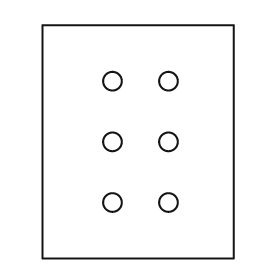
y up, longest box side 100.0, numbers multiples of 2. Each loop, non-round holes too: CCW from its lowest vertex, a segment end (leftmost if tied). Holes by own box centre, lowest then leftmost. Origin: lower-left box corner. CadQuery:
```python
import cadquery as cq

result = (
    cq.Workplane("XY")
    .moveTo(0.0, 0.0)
    .lineTo(82.0, 0.0)
    .lineTo(82.0, 100.0)
    .lineTo(0.0, 100.0)
    .close()
    .moveTo(30.0, 24.0)
    .circle(4.0)
    .moveTo(54.0, 24.0)
    .circle(4.0)
    .moveTo(30.0, 50.0)
    .circle(4.0)
    .moveTo(54.0, 50.0)
    .circle(4.0)
    .moveTo(30.0, 76.0)
    .circle(4.0)
    .moveTo(54.0, 76.0)
    .circle(4.0)
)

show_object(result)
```